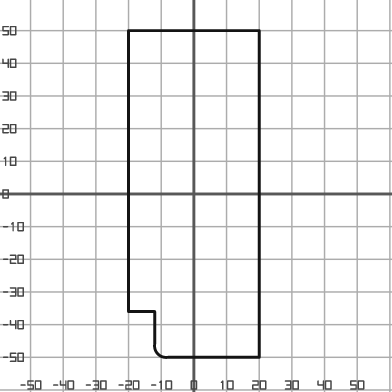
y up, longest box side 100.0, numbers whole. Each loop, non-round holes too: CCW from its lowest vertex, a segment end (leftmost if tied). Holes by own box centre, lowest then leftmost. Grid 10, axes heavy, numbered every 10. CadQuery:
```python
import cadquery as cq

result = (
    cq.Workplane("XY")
    .moveTo(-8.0, -50.0)
    .lineTo(20.0, -50.0)
    .lineTo(20.0, 50.0)
    .lineTo(-20.0, 50.0)
    .lineTo(-20.0, -36.0)
    .lineTo(-12.0, -36.0)
    .lineTo(-12.0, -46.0)
    .threePointArc((-11.0, -49.0), (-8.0, -50.0))
    .close()
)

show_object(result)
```